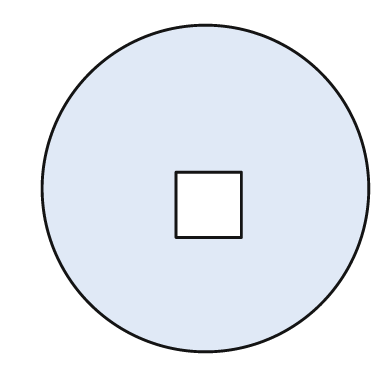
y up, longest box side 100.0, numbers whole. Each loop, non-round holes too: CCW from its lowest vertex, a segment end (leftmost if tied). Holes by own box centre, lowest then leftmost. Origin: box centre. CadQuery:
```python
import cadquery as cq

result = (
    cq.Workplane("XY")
    .moveTo(0.0, 0.0)
    .circle(50.0)
    .moveTo(-9.0, -15.0)
    .lineTo(11.0, -15.0)
    .lineTo(11.0, 5.0)
    .lineTo(-9.0, 5.0)
    .close()
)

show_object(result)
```